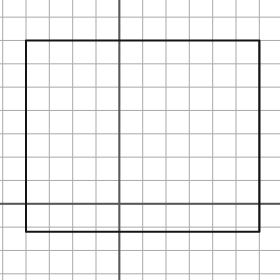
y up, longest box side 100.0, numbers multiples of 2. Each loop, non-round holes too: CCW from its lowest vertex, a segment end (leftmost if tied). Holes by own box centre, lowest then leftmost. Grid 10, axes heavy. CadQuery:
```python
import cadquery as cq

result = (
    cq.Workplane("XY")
    .moveTo(-40.0, -12.0)
    .lineTo(60.0, -12.0)
    .lineTo(60.0, 70.0)
    .lineTo(-40.0, 70.0)
    .close()
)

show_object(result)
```